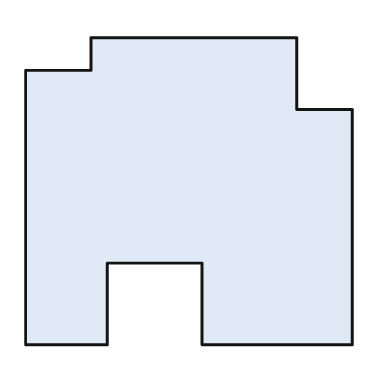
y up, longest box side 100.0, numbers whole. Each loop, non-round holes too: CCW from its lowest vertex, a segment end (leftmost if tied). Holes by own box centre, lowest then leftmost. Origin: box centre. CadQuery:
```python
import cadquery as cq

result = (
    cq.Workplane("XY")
    .moveTo(-50.0, -47.0)
    .lineTo(-25.0, -47.0)
    .lineTo(-25.0, -22.0)
    .lineTo(4.0, -22.0)
    .lineTo(4.0, -47.0)
    .lineTo(50.0, -47.0)
    .lineTo(50.0, 25.0)
    .lineTo(33.0, 25.0)
    .lineTo(33.0, 47.0)
    .lineTo(-30.0, 47.0)
    .lineTo(-30.0, 37.0)
    .lineTo(-50.0, 37.0)
    .close()
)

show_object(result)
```